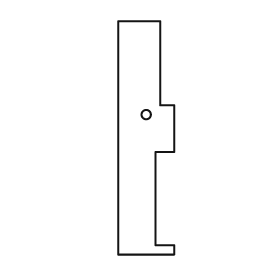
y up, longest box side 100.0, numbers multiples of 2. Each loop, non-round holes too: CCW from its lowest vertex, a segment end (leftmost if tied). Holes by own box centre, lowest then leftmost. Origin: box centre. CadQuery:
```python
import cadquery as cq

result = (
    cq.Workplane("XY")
    .moveTo(-12.0, -50.0)
    .lineTo(12.0, -50.0)
    .lineTo(12.0, -46.0)
    .lineTo(4.0, -46.0)
    .lineTo(4.0, -6.0)
    .lineTo(12.0, -6.0)
    .lineTo(12.0, 14.0)
    .lineTo(6.0, 14.0)
    .lineTo(6.0, 50.0)
    .lineTo(-12.0, 50.0)
    .close()
    .moveTo(0.0, 10.0)
    .circle(2.0)
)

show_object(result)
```